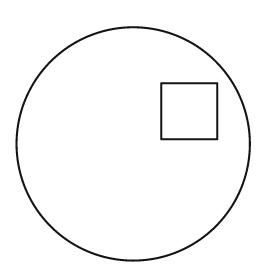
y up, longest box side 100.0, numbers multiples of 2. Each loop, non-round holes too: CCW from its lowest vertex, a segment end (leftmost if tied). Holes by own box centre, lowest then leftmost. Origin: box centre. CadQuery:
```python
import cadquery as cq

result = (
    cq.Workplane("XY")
    .moveTo(0.0, 0.0)
    .circle(50.0)
    .moveTo(12.0, 2.0)
    .lineTo(36.0, 2.0)
    .lineTo(36.0, 26.0)
    .lineTo(12.0, 26.0)
    .close()
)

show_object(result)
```